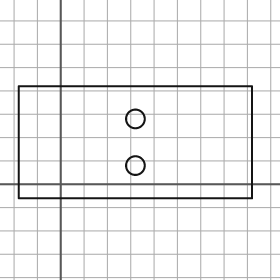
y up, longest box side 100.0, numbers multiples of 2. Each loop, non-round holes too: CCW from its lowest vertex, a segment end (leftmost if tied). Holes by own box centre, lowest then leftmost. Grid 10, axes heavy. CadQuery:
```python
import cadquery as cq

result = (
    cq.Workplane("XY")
    .moveTo(-18.0, -6.0)
    .lineTo(82.0, -6.0)
    .lineTo(82.0, 42.0)
    .lineTo(-18.0, 42.0)
    .close()
    .moveTo(32.0, 8.0)
    .circle(4.0)
    .moveTo(32.0, 28.0)
    .circle(4.0)
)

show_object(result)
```